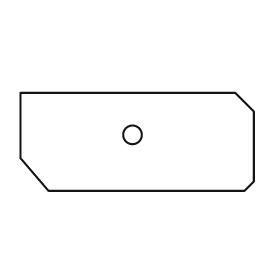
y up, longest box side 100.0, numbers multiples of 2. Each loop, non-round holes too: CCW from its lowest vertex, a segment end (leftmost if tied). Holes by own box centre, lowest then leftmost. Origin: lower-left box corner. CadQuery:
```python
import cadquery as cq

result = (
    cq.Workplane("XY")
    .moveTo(12.0, 0.0)
    .lineTo(96.0, 0.0)
    .lineTo(100.0, 4.0)
    .lineTo(100.0, 34.0)
    .lineTo(92.0, 42.0)
    .lineTo(0.0, 42.0)
    .lineTo(0.0, 14.0)
    .close()
    .moveTo(48.0, 24.0)
    .circle(4.0)
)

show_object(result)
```